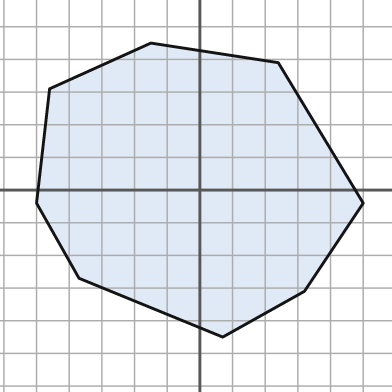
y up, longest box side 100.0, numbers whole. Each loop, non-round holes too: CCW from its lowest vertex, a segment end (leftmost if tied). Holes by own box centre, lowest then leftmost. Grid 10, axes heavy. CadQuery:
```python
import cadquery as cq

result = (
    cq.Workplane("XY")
    .moveTo(7.0, -45.0)
    .lineTo(32.0, -31.0)
    .lineTo(50.0, -4.0)
    .lineTo(24.0, 39.0)
    .lineTo(-15.0, 45.0)
    .lineTo(-46.0, 31.0)
    .lineTo(-50.0, -4.0)
    .lineTo(-37.0, -27.0)
    .close()
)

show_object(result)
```